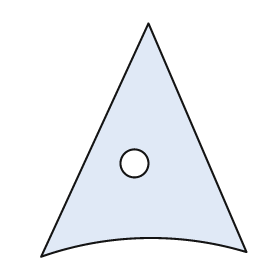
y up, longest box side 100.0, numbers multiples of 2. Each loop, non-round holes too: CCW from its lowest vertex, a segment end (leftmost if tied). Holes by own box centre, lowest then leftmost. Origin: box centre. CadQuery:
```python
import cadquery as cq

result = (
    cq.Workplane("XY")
    .moveTo(-44.0, -50.0)
    .threePointArc((0.0, -42.0), (44.0, -48.0))
    .lineTo(2.0, 50.0)
    .close()
    .moveTo(-4.0, -10.0)
    .circle(6.0)
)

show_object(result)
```